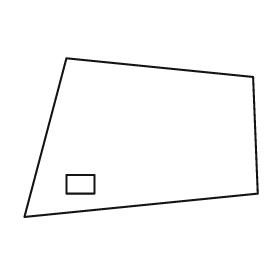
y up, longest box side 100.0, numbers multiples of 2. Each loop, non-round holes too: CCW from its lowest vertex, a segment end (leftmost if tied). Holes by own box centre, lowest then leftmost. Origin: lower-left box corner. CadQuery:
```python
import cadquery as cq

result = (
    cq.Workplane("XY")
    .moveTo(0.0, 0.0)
    .lineTo(100.0, 10.0)
    .lineTo(98.0, 60.0)
    .lineTo(18.0, 68.0)
    .close()
    .moveTo(18.0, 10.0)
    .lineTo(30.0, 10.0)
    .lineTo(30.0, 18.0)
    .lineTo(18.0, 18.0)
    .close()
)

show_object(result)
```